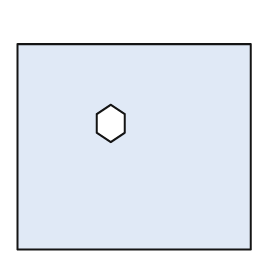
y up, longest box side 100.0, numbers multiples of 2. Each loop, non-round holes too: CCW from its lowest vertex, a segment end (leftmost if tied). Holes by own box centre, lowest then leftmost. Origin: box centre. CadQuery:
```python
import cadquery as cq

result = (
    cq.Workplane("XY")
    .moveTo(-50.0, -44.0)
    .lineTo(50.0, -44.0)
    .lineTo(50.0, 44.0)
    .lineTo(-50.0, 44.0)
    .close()
    .moveTo(-10.0, 2.0)
    .lineTo(-4.0, 6.0)
    .lineTo(-4.0, 14.0)
    .lineTo(-10.0, 18.0)
    .lineTo(-16.0, 14.0)
    .lineTo(-16.0, 6.0)
    .close()
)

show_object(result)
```